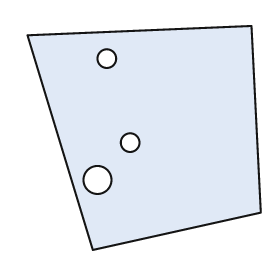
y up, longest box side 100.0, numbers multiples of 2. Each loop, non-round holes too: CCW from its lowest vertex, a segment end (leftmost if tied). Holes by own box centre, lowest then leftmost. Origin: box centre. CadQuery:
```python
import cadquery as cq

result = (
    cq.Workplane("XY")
    .moveTo(-22.0, -48.0)
    .lineTo(50.0, -32.0)
    .lineTo(46.0, 48.0)
    .lineTo(-50.0, 44.0)
    .close()
    .moveTo(-20.0, -18.0)
    .circle(6.0)
    .moveTo(-6.0, -2.0)
    .circle(4.0)
    .moveTo(-16.0, 34.0)
    .circle(4.0)
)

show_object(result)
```